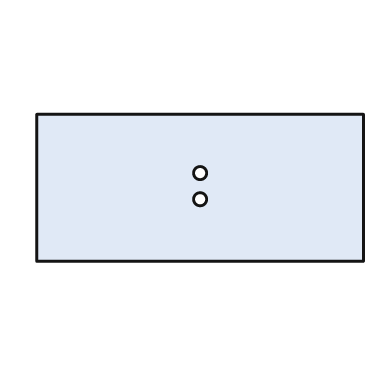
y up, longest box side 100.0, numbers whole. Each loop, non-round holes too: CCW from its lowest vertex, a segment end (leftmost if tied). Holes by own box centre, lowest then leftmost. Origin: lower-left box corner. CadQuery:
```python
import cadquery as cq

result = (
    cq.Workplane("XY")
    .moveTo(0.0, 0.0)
    .lineTo(100.0, 0.0)
    .lineTo(100.0, 45.0)
    .lineTo(0.0, 45.0)
    .close()
    .moveTo(50.0, 19.0)
    .circle(2.0)
    .moveTo(50.0, 27.0)
    .circle(2.0)
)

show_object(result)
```